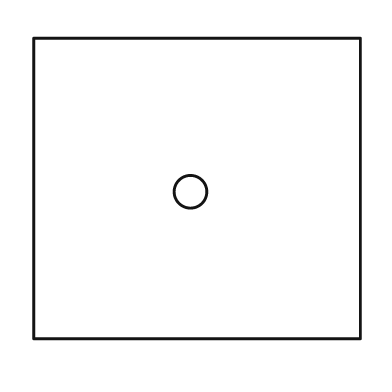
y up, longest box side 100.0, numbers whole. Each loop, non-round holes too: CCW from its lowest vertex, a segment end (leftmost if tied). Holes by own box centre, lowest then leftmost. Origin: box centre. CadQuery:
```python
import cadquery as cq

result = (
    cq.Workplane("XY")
    .moveTo(-50.0, -46.0)
    .lineTo(50.0, -46.0)
    .lineTo(50.0, 46.0)
    .lineTo(-50.0, 46.0)
    .close()
    .moveTo(-2.0, -1.0)
    .circle(5.0)
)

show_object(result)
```